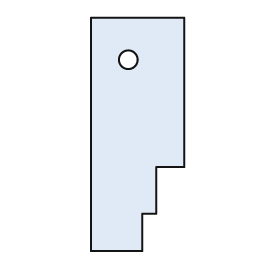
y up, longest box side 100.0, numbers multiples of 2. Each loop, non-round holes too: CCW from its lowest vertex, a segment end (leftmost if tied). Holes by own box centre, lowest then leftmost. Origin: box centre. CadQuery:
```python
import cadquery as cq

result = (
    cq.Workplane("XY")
    .moveTo(-20.0, -50.0)
    .lineTo(2.0, -50.0)
    .lineTo(2.0, -34.0)
    .lineTo(8.0, -34.0)
    .lineTo(8.0, -14.0)
    .lineTo(20.0, -14.0)
    .lineTo(20.0, 50.0)
    .lineTo(-20.0, 50.0)
    .close()
    .moveTo(-4.0, 32.0)
    .circle(4.0)
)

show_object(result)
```